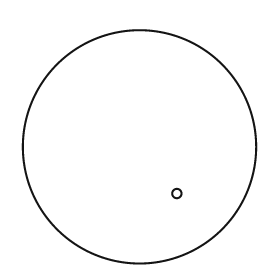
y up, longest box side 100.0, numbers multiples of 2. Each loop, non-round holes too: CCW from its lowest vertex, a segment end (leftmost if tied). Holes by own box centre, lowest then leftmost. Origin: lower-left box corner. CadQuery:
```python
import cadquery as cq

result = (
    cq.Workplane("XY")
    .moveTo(50.0, 50.0)
    .circle(50.0)
    .moveTo(66.0, 30.0)
    .circle(2.0)
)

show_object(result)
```